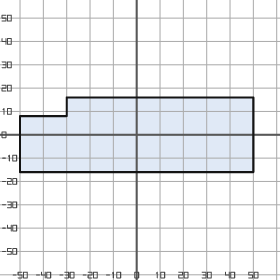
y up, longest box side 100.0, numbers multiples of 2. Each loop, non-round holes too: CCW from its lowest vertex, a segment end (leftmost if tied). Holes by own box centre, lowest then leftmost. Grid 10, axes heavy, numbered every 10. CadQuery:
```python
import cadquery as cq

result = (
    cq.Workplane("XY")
    .moveTo(-50.0, -16.0)
    .lineTo(50.0, -16.0)
    .lineTo(50.0, 16.0)
    .lineTo(-30.0, 16.0)
    .lineTo(-30.0, 8.0)
    .lineTo(-50.0, 8.0)
    .close()
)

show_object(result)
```